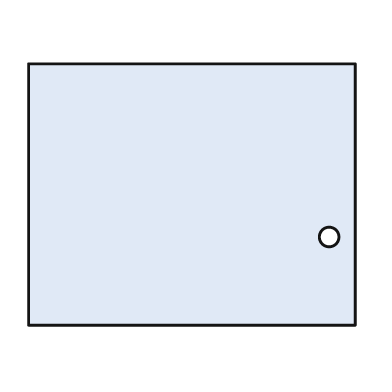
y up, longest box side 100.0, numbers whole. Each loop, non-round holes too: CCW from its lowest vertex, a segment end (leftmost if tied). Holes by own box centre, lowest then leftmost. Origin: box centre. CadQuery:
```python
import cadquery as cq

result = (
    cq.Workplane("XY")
    .moveTo(-50.0, -40.0)
    .lineTo(50.0, -40.0)
    .lineTo(50.0, 40.0)
    .lineTo(-50.0, 40.0)
    .close()
    .moveTo(42.0, -13.0)
    .circle(3.0)
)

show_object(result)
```